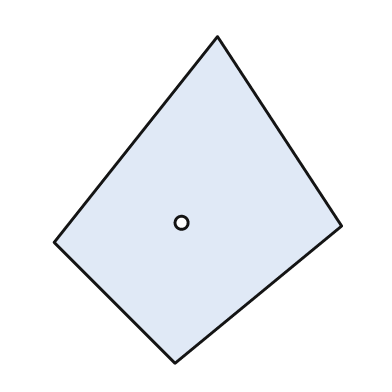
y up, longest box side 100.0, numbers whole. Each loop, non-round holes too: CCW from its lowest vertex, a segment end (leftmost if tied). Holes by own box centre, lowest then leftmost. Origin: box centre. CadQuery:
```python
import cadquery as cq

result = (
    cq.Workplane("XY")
    .moveTo(-7.0, -50.0)
    .lineTo(44.0, -8.0)
    .lineTo(6.0, 50.0)
    .lineTo(-44.0, -13.0)
    .close()
    .moveTo(-5.0, -7.0)
    .circle(2.0)
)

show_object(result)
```